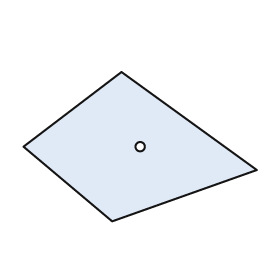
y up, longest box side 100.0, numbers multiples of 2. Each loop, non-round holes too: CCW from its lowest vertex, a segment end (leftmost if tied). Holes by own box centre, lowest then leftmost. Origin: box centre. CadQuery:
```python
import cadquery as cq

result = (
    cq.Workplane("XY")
    .moveTo(-12.0, -32.0)
    .lineTo(50.0, -10.0)
    .lineTo(-8.0, 32.0)
    .lineTo(-50.0, 0.0)
    .close()
    .moveTo(0.0, 0.0)
    .circle(2.0)
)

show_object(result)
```